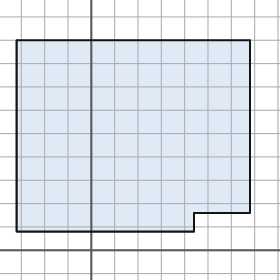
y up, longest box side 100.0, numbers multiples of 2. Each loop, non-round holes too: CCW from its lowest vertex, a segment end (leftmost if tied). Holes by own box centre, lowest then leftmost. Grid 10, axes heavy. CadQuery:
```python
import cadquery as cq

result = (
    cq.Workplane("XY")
    .moveTo(-32.0, 8.0)
    .lineTo(44.0, 8.0)
    .lineTo(44.0, 16.0)
    .lineTo(68.0, 16.0)
    .lineTo(68.0, 90.0)
    .lineTo(-32.0, 90.0)
    .close()
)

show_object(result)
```